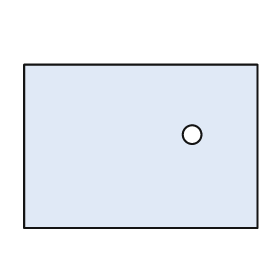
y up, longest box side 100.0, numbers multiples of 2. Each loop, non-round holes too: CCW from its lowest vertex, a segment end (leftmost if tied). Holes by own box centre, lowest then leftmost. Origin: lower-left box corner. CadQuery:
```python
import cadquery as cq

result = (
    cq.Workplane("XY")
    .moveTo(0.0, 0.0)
    .lineTo(100.0, 0.0)
    .lineTo(100.0, 70.0)
    .lineTo(0.0, 70.0)
    .close()
    .moveTo(72.0, 40.0)
    .circle(4.0)
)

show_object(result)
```